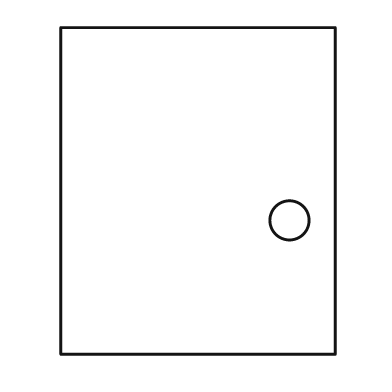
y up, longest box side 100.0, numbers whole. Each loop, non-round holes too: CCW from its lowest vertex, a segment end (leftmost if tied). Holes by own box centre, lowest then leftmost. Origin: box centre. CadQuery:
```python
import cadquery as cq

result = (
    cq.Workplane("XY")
    .moveTo(-42.0, -50.0)
    .lineTo(42.0, -50.0)
    .lineTo(42.0, 50.0)
    .lineTo(-42.0, 50.0)
    .close()
    .moveTo(28.0, -9.0)
    .circle(6.0)
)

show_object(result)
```